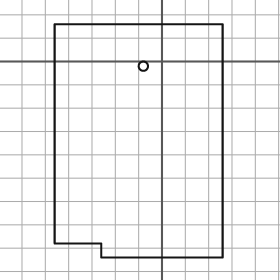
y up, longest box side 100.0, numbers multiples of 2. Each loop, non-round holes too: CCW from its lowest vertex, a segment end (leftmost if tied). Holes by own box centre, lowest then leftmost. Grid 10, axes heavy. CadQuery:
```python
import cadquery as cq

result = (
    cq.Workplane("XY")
    .moveTo(-26.0, -84.0)
    .lineTo(26.0, -84.0)
    .lineTo(26.0, 16.0)
    .lineTo(-46.0, 16.0)
    .lineTo(-46.0, -78.0)
    .lineTo(-26.0, -78.0)
    .close()
    .moveTo(-8.0, -2.0)
    .circle(2.0)
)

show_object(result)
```